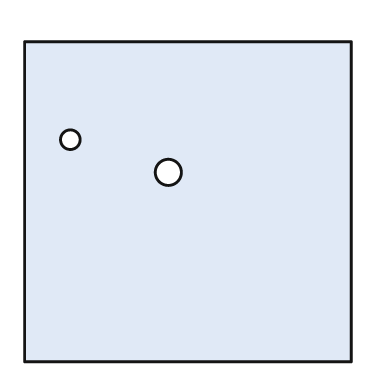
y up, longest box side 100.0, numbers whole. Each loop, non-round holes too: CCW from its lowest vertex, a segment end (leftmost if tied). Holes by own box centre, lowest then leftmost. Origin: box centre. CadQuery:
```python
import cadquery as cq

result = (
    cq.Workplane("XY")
    .moveTo(-50.0, -49.0)
    .lineTo(50.0, -49.0)
    .lineTo(50.0, 49.0)
    .lineTo(-50.0, 49.0)
    .close()
    .moveTo(-6.0, 9.0)
    .circle(4.0)
    .moveTo(-36.0, 19.0)
    .circle(3.0)
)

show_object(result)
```